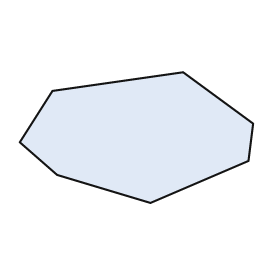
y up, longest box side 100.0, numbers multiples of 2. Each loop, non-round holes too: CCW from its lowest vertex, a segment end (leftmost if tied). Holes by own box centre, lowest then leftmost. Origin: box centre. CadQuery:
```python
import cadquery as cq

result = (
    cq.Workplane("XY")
    .moveTo(6.0, -28.0)
    .lineTo(48.0, -10.0)
    .lineTo(50.0, 6.0)
    .lineTo(20.0, 28.0)
    .lineTo(-36.0, 20.0)
    .lineTo(-50.0, -2.0)
    .lineTo(-34.0, -16.0)
    .close()
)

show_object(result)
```